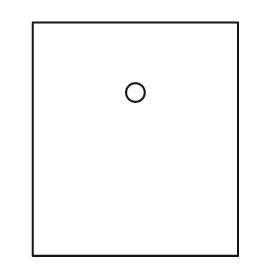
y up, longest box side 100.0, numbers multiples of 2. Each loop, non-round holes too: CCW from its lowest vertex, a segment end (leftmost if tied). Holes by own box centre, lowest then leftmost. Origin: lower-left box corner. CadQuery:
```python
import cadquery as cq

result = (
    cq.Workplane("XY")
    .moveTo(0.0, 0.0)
    .lineTo(88.0, 0.0)
    .lineTo(88.0, 100.0)
    .lineTo(0.0, 100.0)
    .close()
    .moveTo(44.0, 70.0)
    .circle(4.0)
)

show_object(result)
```